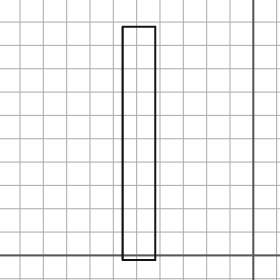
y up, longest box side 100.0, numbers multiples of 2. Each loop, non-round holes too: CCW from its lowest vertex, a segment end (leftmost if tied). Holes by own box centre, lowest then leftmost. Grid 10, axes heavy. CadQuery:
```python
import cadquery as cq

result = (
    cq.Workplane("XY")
    .moveTo(-56.0, -2.0)
    .lineTo(-42.0, -2.0)
    .lineTo(-42.0, 98.0)
    .lineTo(-56.0, 98.0)
    .close()
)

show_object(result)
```